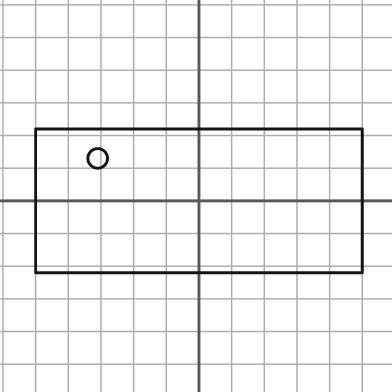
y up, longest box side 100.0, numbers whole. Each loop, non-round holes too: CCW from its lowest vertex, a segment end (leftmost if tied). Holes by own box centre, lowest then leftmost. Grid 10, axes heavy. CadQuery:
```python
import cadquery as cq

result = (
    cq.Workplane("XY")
    .moveTo(-50.0, -22.0)
    .lineTo(50.0, -22.0)
    .lineTo(50.0, 22.0)
    .lineTo(-50.0, 22.0)
    .close()
    .moveTo(-31.0, 13.0)
    .circle(3.0)
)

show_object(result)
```